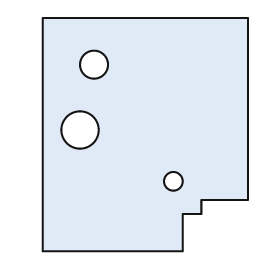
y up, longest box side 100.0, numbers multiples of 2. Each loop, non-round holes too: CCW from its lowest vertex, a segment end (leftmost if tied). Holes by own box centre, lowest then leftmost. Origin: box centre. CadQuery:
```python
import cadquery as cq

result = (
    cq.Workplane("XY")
    .moveTo(-44.0, -50.0)
    .lineTo(16.0, -50.0)
    .lineTo(16.0, -34.0)
    .lineTo(24.0, -34.0)
    .lineTo(24.0, -28.0)
    .lineTo(44.0, -28.0)
    .lineTo(44.0, 50.0)
    .lineTo(-44.0, 50.0)
    .close()
    .moveTo(12.0, -20.0)
    .circle(4.0)
    .moveTo(-28.0, 2.0)
    .circle(8.0)
    .moveTo(-22.0, 30.0)
    .circle(6.0)
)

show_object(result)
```